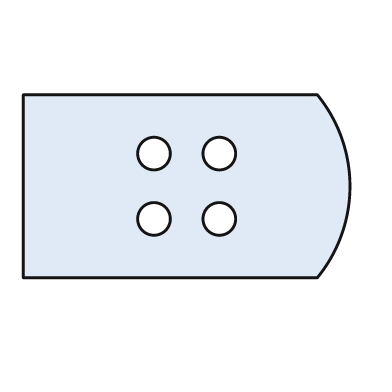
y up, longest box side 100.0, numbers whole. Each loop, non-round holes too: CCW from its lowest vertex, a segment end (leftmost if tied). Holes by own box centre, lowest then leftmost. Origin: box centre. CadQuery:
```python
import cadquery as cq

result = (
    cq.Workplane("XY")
    .moveTo(-50.0, -28.0)
    .lineTo(40.0, -28.0)
    .threePointArc((50.0, 0.0), (40.0, 28.0))
    .lineTo(-50.0, 28.0)
    .close()
    .moveTo(-10.0, -10.0)
    .circle(5.0)
    .moveTo(10.0, -10.0)
    .circle(5.0)
    .moveTo(-10.0, 10.0)
    .circle(5.0)
    .moveTo(10.0, 10.0)
    .circle(5.0)
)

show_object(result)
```